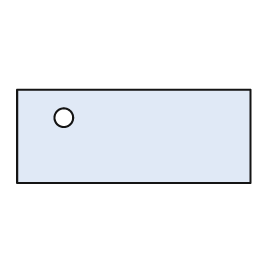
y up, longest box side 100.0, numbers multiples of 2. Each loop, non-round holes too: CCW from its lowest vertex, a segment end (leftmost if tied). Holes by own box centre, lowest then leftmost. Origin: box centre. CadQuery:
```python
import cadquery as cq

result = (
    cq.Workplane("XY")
    .moveTo(-50.0, -20.0)
    .lineTo(50.0, -20.0)
    .lineTo(50.0, 20.0)
    .lineTo(-50.0, 20.0)
    .close()
    .moveTo(-30.0, 8.0)
    .circle(4.0)
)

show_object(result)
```